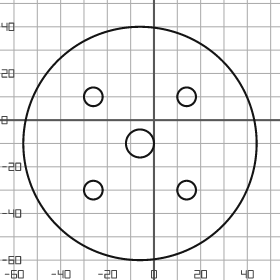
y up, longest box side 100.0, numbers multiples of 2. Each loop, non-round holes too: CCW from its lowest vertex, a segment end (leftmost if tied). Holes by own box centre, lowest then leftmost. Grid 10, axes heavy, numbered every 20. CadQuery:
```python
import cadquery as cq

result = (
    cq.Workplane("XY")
    .moveTo(-6.0, -10.0)
    .circle(50.0)
    .moveTo(-26.0, -30.0)
    .circle(4.0)
    .moveTo(14.0, -30.0)
    .circle(4.0)
    .moveTo(-6.0, -10.0)
    .circle(6.0)
    .moveTo(-26.0, 10.0)
    .circle(4.0)
    .moveTo(14.0, 10.0)
    .circle(4.0)
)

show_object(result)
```